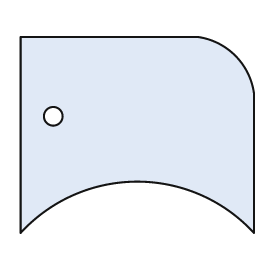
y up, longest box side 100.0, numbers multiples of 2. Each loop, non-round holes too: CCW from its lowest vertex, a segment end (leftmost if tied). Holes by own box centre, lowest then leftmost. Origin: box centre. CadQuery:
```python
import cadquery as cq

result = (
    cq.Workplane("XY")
    .moveTo(-50.0, -42.0)
    .threePointArc((0.0, -20.0), (50.0, -42.0))
    .lineTo(50.0, 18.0)
    .threePointArc((42.0, 34.0), (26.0, 42.0))
    .lineTo(-50.0, 42.0)
    .close()
    .moveTo(-36.0, 8.0)
    .circle(4.0)
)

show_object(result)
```